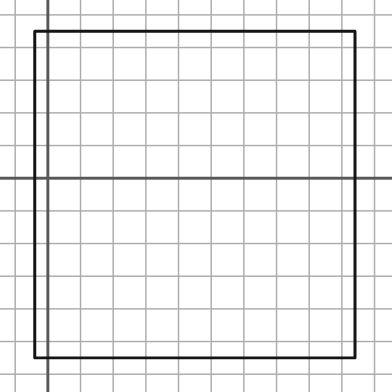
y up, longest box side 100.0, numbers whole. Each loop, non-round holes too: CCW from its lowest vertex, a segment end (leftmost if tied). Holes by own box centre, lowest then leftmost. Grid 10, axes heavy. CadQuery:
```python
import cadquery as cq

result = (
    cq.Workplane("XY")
    .moveTo(-4.0, -55.0)
    .lineTo(94.0, -55.0)
    .lineTo(94.0, 45.0)
    .lineTo(-4.0, 45.0)
    .close()
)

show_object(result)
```